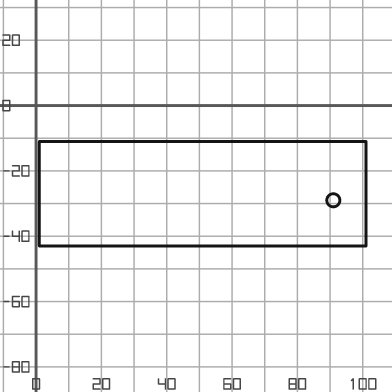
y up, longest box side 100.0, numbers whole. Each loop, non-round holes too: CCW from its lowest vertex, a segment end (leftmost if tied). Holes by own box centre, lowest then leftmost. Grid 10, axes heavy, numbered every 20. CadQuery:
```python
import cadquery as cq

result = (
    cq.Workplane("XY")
    .moveTo(1.0, -43.0)
    .lineTo(101.0, -43.0)
    .lineTo(101.0, -11.0)
    .lineTo(1.0, -11.0)
    .close()
    .moveTo(91.0, -29.0)
    .circle(2.0)
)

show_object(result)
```